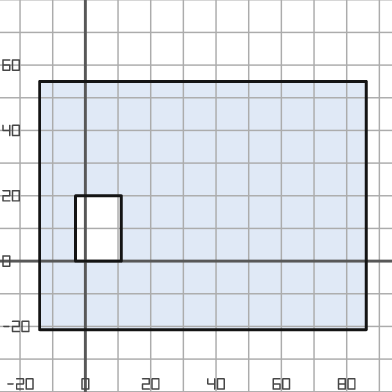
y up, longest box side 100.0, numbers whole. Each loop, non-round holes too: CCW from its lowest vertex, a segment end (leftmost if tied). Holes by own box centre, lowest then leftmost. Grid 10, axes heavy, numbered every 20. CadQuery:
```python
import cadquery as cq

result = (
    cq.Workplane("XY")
    .moveTo(-14.0, -21.0)
    .lineTo(86.0, -21.0)
    .lineTo(86.0, 55.0)
    .lineTo(-14.0, 55.0)
    .close()
    .moveTo(-3.0, 0.0)
    .lineTo(11.0, 0.0)
    .lineTo(11.0, 20.0)
    .lineTo(-3.0, 20.0)
    .close()
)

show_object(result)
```